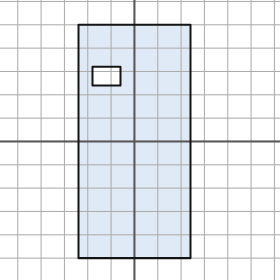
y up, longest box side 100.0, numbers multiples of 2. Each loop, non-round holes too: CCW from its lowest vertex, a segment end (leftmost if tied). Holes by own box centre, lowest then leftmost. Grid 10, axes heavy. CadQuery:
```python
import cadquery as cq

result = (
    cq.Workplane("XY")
    .moveTo(-24.0, -50.0)
    .lineTo(24.0, -50.0)
    .lineTo(24.0, 50.0)
    .lineTo(-24.0, 50.0)
    .close()
    .moveTo(-18.0, 24.0)
    .lineTo(-6.0, 24.0)
    .lineTo(-6.0, 32.0)
    .lineTo(-18.0, 32.0)
    .close()
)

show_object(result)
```